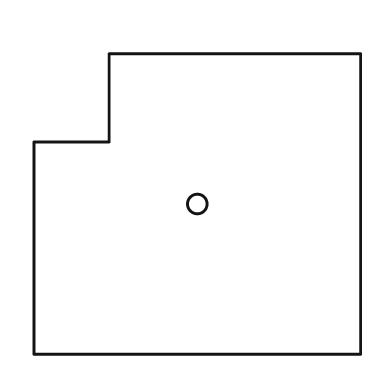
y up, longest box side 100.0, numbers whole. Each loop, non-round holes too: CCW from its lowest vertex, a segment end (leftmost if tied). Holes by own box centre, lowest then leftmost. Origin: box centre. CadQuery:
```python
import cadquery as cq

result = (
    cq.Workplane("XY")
    .moveTo(-50.0, -46.0)
    .lineTo(50.0, -46.0)
    .lineTo(50.0, 46.0)
    .lineTo(-27.0, 46.0)
    .lineTo(-27.0, 19.0)
    .lineTo(-50.0, 19.0)
    .close()
    .moveTo(0.0, 0.0)
    .circle(3.0)
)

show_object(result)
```